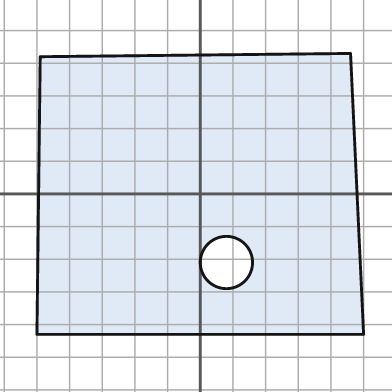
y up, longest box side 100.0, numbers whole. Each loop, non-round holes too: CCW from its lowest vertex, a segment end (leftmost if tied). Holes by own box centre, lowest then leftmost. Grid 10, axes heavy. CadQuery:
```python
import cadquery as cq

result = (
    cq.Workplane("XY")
    .moveTo(-50.0, -43.0)
    .lineTo(50.0, -43.0)
    .lineTo(46.0, 43.0)
    .lineTo(-49.0, 42.0)
    .close()
    .moveTo(8.0, -21.0)
    .circle(8.0)
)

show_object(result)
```